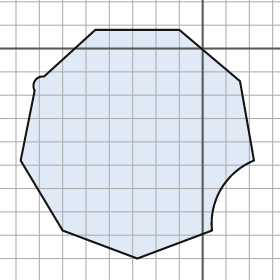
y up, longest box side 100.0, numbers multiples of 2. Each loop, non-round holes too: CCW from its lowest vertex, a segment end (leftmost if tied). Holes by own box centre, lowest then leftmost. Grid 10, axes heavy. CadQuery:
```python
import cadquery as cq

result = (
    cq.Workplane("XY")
    .moveTo(-28.0, -90.0)
    .lineTo(4.0, -78.0)
    .threePointArc((8.0, -60.0), (22.0, -48.0))
    .lineTo(16.0, -14.0)
    .lineTo(-10.0, 8.0)
    .lineTo(-46.0, 8.0)
    .lineTo(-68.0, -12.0)
    .threePointArc((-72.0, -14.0), (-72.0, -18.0))
    .lineTo(-78.0, -48.0)
    .lineTo(-60.0, -78.0)
    .close()
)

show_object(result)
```